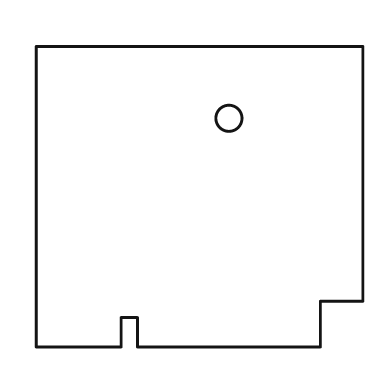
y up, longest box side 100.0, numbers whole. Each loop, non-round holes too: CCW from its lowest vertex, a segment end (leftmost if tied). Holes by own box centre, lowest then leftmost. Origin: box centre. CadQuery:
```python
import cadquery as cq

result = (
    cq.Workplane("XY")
    .moveTo(-50.0, -46.0)
    .lineTo(-24.0, -46.0)
    .lineTo(-24.0, -37.0)
    .lineTo(-19.0, -37.0)
    .lineTo(-19.0, -46.0)
    .lineTo(37.0, -46.0)
    .lineTo(37.0, -32.0)
    .lineTo(50.0, -32.0)
    .lineTo(50.0, 46.0)
    .lineTo(-50.0, 46.0)
    .close()
    .moveTo(9.0, 24.0)
    .circle(4.0)
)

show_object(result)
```